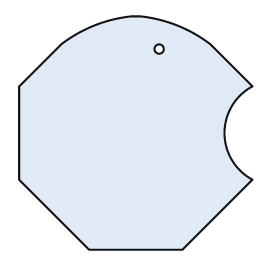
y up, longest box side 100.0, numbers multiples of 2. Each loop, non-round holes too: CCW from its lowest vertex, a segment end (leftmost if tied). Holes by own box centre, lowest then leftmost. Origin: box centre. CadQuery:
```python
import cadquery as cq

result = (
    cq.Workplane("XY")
    .moveTo(-20.0, -50.0)
    .lineTo(20.0, -50.0)
    .lineTo(50.0, -20.0)
    .threePointArc((38.0, 0.0), (50.0, 20.0))
    .lineTo(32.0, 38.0)
    .threePointArc((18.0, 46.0), (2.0, 50.0))
    .lineTo(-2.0, 50.0)
    .threePointArc((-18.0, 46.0), (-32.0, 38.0))
    .lineTo(-50.0, 20.0)
    .lineTo(-50.0, -20.0)
    .close()
    .moveTo(10.0, 36.0)
    .circle(2.0)
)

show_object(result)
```